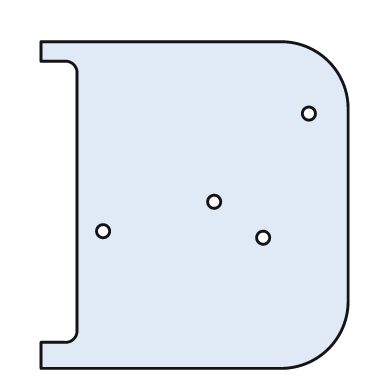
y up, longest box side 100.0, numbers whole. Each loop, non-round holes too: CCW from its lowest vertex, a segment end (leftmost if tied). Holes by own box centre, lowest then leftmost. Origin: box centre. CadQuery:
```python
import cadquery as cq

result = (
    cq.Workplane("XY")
    .moveTo(-47.0, -50.0)
    .lineTo(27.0, -50.0)
    .threePointArc((41.0, -44.0), (47.0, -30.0))
    .lineTo(47.0, 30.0)
    .threePointArc((41.0, 44.0), (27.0, 50.0))
    .lineTo(-47.0, 50.0)
    .lineTo(-47.0, 44.0)
    .lineTo(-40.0, 44.0)
    .threePointArc((-37.0, 43.0), (-36.0, 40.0))
    .lineTo(-36.0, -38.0)
    .threePointArc((-37.0, -41.0), (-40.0, -42.0))
    .lineTo(-47.0, -42.0)
    .close()
    .moveTo(21.0, -10.0)
    .circle(2.0)
    .moveTo(-28.0, -8.0)
    .circle(2.0)
    .moveTo(6.0, 1.0)
    .circle(2.0)
    .moveTo(35.0, 28.0)
    .circle(2.0)
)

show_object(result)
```